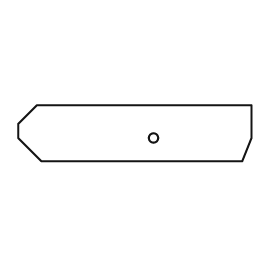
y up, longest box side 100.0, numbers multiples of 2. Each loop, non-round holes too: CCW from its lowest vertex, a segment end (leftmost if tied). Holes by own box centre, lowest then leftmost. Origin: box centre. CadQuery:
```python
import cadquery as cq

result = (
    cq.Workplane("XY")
    .moveTo(-40.0, -12.0)
    .lineTo(46.0, -12.0)
    .lineTo(50.0, -2.0)
    .lineTo(50.0, 12.0)
    .lineTo(-42.0, 12.0)
    .lineTo(-50.0, 4.0)
    .lineTo(-50.0, -2.0)
    .close()
    .moveTo(8.0, -2.0)
    .circle(2.0)
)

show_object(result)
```